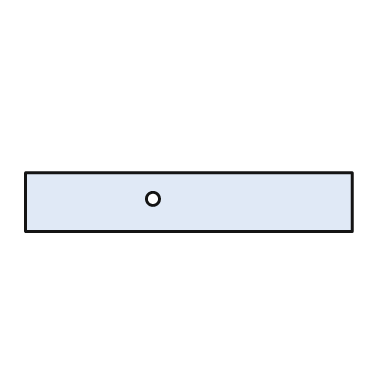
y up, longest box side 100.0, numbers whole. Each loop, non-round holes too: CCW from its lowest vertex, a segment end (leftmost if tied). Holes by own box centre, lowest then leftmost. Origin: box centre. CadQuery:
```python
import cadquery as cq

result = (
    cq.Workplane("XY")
    .moveTo(-50.0, -9.0)
    .lineTo(50.0, -9.0)
    .lineTo(50.0, 9.0)
    .lineTo(-50.0, 9.0)
    .close()
    .moveTo(-11.0, 1.0)
    .circle(2.0)
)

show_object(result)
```